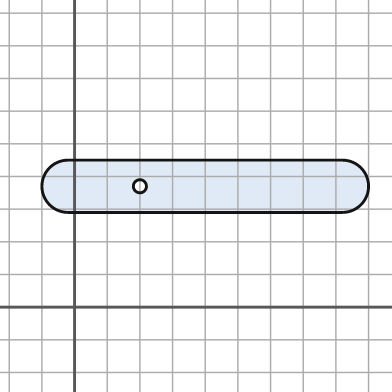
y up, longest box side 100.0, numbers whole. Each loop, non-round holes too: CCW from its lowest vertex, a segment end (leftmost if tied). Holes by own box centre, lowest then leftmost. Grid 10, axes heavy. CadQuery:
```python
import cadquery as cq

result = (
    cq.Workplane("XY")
    .moveTo(-2.0, 29.0)
    .lineTo(82.0, 29.0)
    .threePointArc((90.0, 37.0), (82.0, 45.0))
    .lineTo(-2.0, 45.0)
    .threePointArc((-10.0, 37.0), (-2.0, 29.0))
    .close()
    .moveTo(20.0, 37.0)
    .circle(2.0)
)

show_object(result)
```